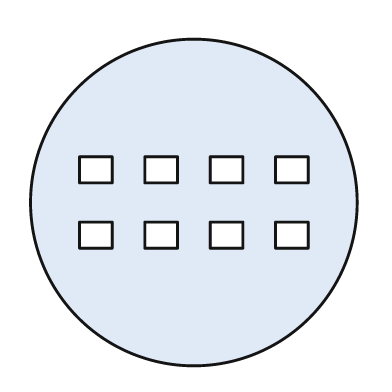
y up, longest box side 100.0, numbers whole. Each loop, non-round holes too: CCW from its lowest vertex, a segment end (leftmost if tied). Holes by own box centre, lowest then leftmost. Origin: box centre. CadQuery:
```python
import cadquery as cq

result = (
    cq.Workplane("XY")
    .moveTo(0.0, 0.0)
    .circle(50.0)
    .moveTo(-35.0, -14.0)
    .lineTo(-25.0, -14.0)
    .lineTo(-25.0, -6.0)
    .lineTo(-35.0, -6.0)
    .close()
    .moveTo(-15.0, -14.0)
    .lineTo(-5.0, -14.0)
    .lineTo(-5.0, -6.0)
    .lineTo(-15.0, -6.0)
    .close()
    .moveTo(5.0, -14.0)
    .lineTo(15.0, -14.0)
    .lineTo(15.0, -6.0)
    .lineTo(5.0, -6.0)
    .close()
    .moveTo(25.0, -14.0)
    .lineTo(35.0, -14.0)
    .lineTo(35.0, -6.0)
    .lineTo(25.0, -6.0)
    .close()
    .moveTo(-35.0, 6.0)
    .lineTo(-25.0, 6.0)
    .lineTo(-25.0, 14.0)
    .lineTo(-35.0, 14.0)
    .close()
    .moveTo(-15.0, 6.0)
    .lineTo(-5.0, 6.0)
    .lineTo(-5.0, 14.0)
    .lineTo(-15.0, 14.0)
    .close()
    .moveTo(5.0, 6.0)
    .lineTo(15.0, 6.0)
    .lineTo(15.0, 14.0)
    .lineTo(5.0, 14.0)
    .close()
    .moveTo(25.0, 6.0)
    .lineTo(35.0, 6.0)
    .lineTo(35.0, 14.0)
    .lineTo(25.0, 14.0)
    .close()
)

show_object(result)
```